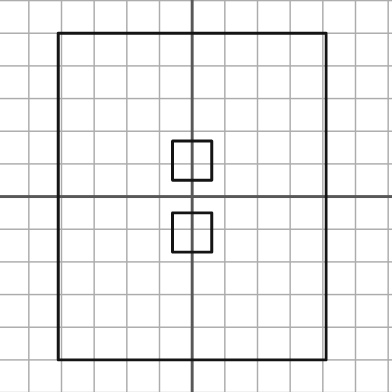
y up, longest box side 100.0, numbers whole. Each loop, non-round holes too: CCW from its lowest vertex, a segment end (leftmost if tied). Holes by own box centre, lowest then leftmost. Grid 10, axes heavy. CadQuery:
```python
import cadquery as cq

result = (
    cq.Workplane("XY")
    .moveTo(-41.0, -50.0)
    .lineTo(41.0, -50.0)
    .lineTo(41.0, 50.0)
    .lineTo(-41.0, 50.0)
    .close()
    .moveTo(-6.0, -17.0)
    .lineTo(6.0, -17.0)
    .lineTo(6.0, -5.0)
    .lineTo(-6.0, -5.0)
    .close()
    .moveTo(-6.0, 5.0)
    .lineTo(6.0, 5.0)
    .lineTo(6.0, 17.0)
    .lineTo(-6.0, 17.0)
    .close()
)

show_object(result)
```